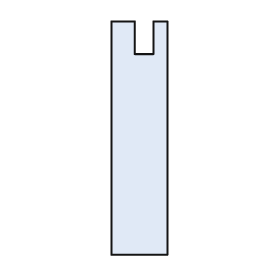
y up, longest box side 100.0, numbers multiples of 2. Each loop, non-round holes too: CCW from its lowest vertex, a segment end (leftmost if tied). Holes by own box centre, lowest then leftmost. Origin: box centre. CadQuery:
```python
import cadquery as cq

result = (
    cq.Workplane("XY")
    .moveTo(-12.0, -50.0)
    .lineTo(12.0, -50.0)
    .lineTo(12.0, 50.0)
    .lineTo(6.0, 50.0)
    .lineTo(6.0, 36.0)
    .lineTo(-2.0, 36.0)
    .lineTo(-2.0, 50.0)
    .lineTo(-12.0, 50.0)
    .close()
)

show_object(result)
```